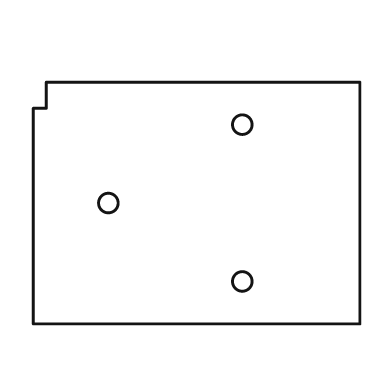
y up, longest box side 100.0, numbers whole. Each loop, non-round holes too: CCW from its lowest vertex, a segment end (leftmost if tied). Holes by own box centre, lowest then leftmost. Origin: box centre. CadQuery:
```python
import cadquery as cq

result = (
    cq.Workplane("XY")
    .moveTo(-50.0, -37.0)
    .lineTo(50.0, -37.0)
    .lineTo(50.0, 37.0)
    .lineTo(-46.0, 37.0)
    .lineTo(-46.0, 29.0)
    .lineTo(-50.0, 29.0)
    .close()
    .moveTo(14.0, -24.0)
    .circle(3.0)
    .moveTo(-27.0, 0.0)
    .circle(3.0)
    .moveTo(14.0, 24.0)
    .circle(3.0)
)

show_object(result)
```